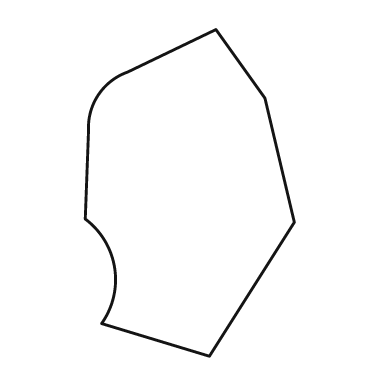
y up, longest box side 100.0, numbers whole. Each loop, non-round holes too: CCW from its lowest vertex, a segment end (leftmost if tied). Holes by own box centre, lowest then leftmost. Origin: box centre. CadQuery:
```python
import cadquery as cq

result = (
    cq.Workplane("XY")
    .moveTo(6.0, -50.0)
    .lineTo(32.0, -9.0)
    .lineTo(23.0, 29.0)
    .lineTo(8.0, 50.0)
    .lineTo(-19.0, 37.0)
    .threePointArc((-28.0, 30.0), (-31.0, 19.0))
    .lineTo(-32.0, -8.0)
    .threePointArc((-23.0, -23.0), (-27.0, -40.0))
    .close()
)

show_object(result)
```